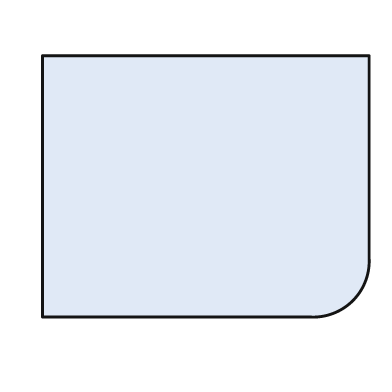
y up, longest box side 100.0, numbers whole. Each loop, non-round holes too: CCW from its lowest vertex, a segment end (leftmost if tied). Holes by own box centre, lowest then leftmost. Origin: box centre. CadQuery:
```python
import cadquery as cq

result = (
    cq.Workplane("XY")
    .moveTo(-50.0, -40.0)
    .lineTo(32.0, -40.0)
    .threePointArc((45.0, -35.0), (50.0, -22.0))
    .lineTo(50.0, 40.0)
    .lineTo(-50.0, 40.0)
    .close()
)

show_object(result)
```